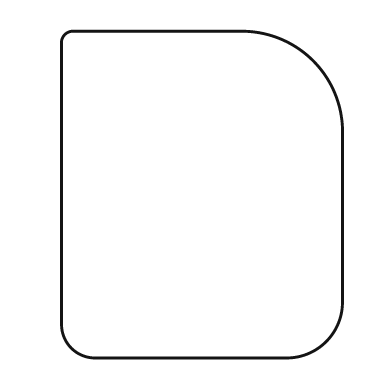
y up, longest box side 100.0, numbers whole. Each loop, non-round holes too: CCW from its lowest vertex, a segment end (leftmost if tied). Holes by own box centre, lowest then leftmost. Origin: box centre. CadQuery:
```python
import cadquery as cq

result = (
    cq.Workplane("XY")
    .moveTo(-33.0, -50.0)
    .lineTo(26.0, -50.0)
    .threePointArc((38.0, -45.0), (43.0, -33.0))
    .lineTo(43.0, 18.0)
    .threePointArc((34.0, 41.0), (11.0, 50.0))
    .lineTo(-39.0, 50.0)
    .threePointArc((-42.0, 49.0), (-43.0, 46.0))
    .lineTo(-43.0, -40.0)
    .threePointArc((-40.0, -47.0), (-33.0, -50.0))
    .close()
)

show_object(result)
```